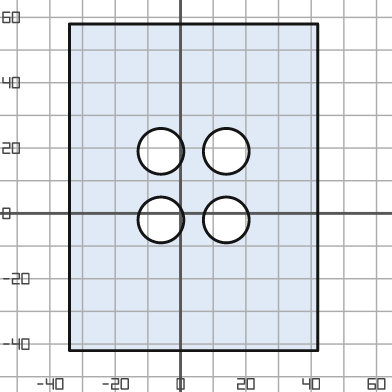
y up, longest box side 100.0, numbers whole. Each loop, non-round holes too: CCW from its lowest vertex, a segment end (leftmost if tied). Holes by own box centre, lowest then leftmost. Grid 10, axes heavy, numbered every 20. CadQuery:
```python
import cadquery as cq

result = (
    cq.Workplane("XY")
    .moveTo(-34.0, -42.0)
    .lineTo(42.0, -42.0)
    .lineTo(42.0, 58.0)
    .lineTo(-34.0, 58.0)
    .close()
    .moveTo(-6.0, -2.0)
    .circle(7.0)
    .moveTo(14.0, -2.0)
    .circle(7.0)
    .moveTo(-6.0, 19.0)
    .circle(7.0)
    .moveTo(14.0, 19.0)
    .circle(7.0)
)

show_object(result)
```